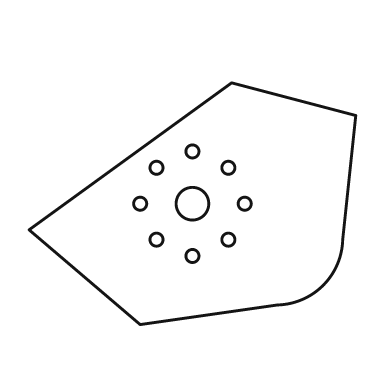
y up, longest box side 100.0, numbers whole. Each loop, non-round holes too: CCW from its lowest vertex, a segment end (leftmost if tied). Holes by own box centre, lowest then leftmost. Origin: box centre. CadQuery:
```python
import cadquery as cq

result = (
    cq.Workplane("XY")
    .moveTo(-16.0, -37.0)
    .lineTo(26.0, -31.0)
    .threePointArc((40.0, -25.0), (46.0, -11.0))
    .lineTo(50.0, 27.0)
    .lineTo(12.0, 37.0)
    .lineTo(-50.0, -8.0)
    .close()
    .moveTo(0.0, -16.0)
    .circle(2.0)
    .moveTo(-11.0, -11.0)
    .circle(2.0)
    .moveTo(11.0, -11.0)
    .circle(2.0)
    .moveTo(-16.0, 0.0)
    .circle(2.0)
    .moveTo(0.0, 0.0)
    .circle(5.0)
    .moveTo(16.0, 0.0)
    .circle(2.0)
    .moveTo(-11.0, 11.0)
    .circle(2.0)
    .moveTo(11.0, 11.0)
    .circle(2.0)
    .moveTo(0.0, 16.0)
    .circle(2.0)
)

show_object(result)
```